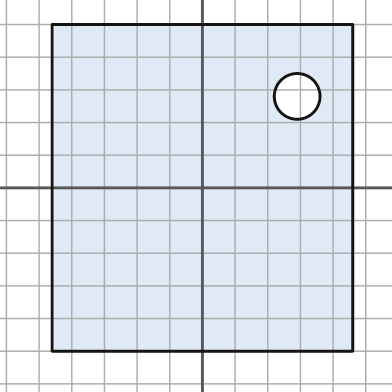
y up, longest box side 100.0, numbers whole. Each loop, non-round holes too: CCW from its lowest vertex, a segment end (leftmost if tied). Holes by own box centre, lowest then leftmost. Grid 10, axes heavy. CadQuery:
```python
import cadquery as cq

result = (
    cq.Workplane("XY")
    .moveTo(-46.0, -50.0)
    .lineTo(46.0, -50.0)
    .lineTo(46.0, 50.0)
    .lineTo(-46.0, 50.0)
    .close()
    .moveTo(29.0, 28.0)
    .circle(7.0)
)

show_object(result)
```